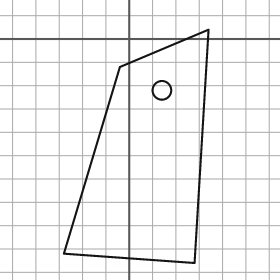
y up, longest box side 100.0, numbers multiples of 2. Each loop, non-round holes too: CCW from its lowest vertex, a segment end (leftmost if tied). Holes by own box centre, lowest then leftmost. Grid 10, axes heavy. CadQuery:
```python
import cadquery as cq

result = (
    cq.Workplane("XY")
    .moveTo(28.0, -96.0)
    .lineTo(34.0, 4.0)
    .lineTo(-4.0, -12.0)
    .lineTo(-28.0, -92.0)
    .close()
    .moveTo(14.0, -22.0)
    .circle(4.0)
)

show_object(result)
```